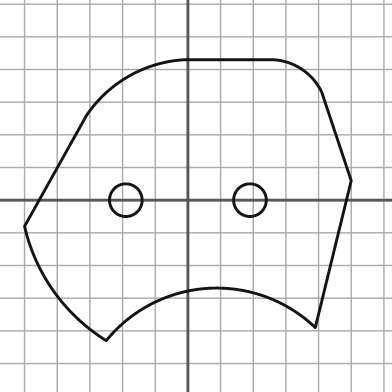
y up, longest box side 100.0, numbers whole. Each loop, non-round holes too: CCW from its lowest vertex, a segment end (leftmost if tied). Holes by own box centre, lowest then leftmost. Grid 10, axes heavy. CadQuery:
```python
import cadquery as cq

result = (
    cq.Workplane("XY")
    .moveTo(-25.0, -43.0)
    .threePointArc((6.0, -27.0), (39.0, -39.0))
    .lineTo(50.0, 6.0)
    .lineTo(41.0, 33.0)
    .threePointArc((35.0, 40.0), (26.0, 43.0))
    .lineTo(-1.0, 43.0)
    .threePointArc((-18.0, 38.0), (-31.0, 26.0))
    .lineTo(-50.0, -8.0)
    .threePointArc((-41.0, -28.0), (-25.0, -43.0))
    .close()
    .moveTo(-19.0, 0.0)
    .circle(5.0)
    .moveTo(19.0, 0.0)
    .circle(5.0)
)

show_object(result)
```